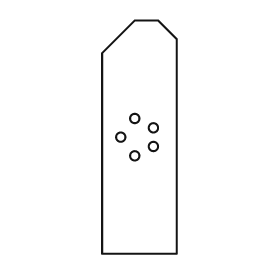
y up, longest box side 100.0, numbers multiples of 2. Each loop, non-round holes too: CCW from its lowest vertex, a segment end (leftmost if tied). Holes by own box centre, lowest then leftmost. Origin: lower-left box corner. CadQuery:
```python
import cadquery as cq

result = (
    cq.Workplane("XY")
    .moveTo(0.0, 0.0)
    .lineTo(32.0, 0.0)
    .lineTo(32.0, 92.0)
    .lineTo(24.0, 100.0)
    .lineTo(14.0, 100.0)
    .lineTo(0.0, 86.0)
    .close()
    .moveTo(14.0, 42.0)
    .circle(2.0)
    .moveTo(22.0, 46.0)
    .circle(2.0)
    .moveTo(8.0, 50.0)
    .circle(2.0)
    .moveTo(22.0, 54.0)
    .circle(2.0)
    .moveTo(14.0, 58.0)
    .circle(2.0)
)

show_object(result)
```